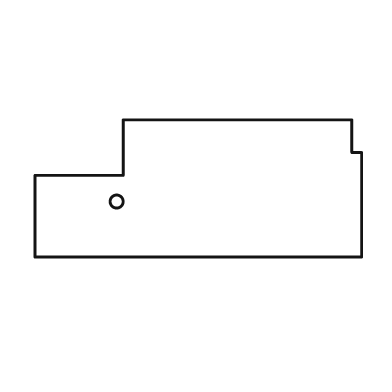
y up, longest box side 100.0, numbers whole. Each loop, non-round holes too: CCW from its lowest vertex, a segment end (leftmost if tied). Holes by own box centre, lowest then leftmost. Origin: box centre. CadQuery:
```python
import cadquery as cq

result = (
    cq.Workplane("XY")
    .moveTo(-50.0, -21.0)
    .lineTo(50.0, -21.0)
    .lineTo(50.0, 11.0)
    .lineTo(47.0, 11.0)
    .lineTo(47.0, 21.0)
    .lineTo(-23.0, 21.0)
    .lineTo(-23.0, 4.0)
    .lineTo(-50.0, 4.0)
    .close()
    .moveTo(-25.0, -4.0)
    .circle(2.0)
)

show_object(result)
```